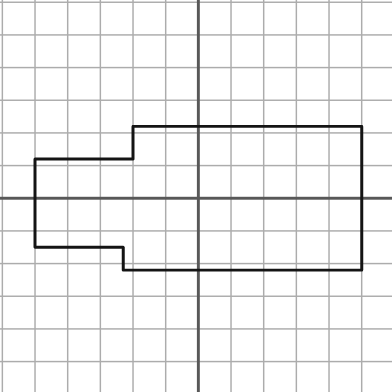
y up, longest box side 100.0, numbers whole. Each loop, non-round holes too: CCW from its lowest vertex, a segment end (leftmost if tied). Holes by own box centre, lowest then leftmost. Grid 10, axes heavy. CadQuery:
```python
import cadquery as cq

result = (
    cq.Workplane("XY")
    .moveTo(-23.0, -22.0)
    .lineTo(50.0, -22.0)
    .lineTo(50.0, 22.0)
    .lineTo(-20.0, 22.0)
    .lineTo(-20.0, 12.0)
    .lineTo(-50.0, 12.0)
    .lineTo(-50.0, -15.0)
    .lineTo(-23.0, -15.0)
    .close()
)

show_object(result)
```